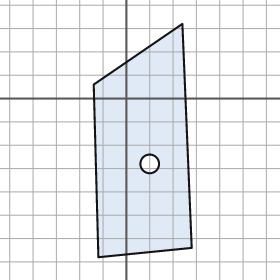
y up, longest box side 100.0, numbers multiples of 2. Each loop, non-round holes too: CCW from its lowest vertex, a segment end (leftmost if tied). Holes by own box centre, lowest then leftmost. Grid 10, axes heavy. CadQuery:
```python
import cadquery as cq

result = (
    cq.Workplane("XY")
    .moveTo(-12.0, -68.0)
    .lineTo(28.0, -64.0)
    .lineTo(24.0, 32.0)
    .lineTo(-14.0, 6.0)
    .close()
    .moveTo(10.0, -28.0)
    .circle(4.0)
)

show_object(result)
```